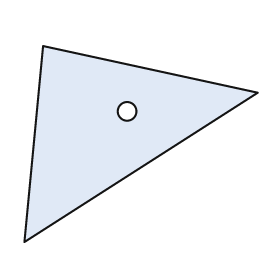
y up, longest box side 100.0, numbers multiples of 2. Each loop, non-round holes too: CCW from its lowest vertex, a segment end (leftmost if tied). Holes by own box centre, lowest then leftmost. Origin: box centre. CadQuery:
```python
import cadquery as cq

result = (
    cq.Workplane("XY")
    .moveTo(-50.0, -42.0)
    .lineTo(50.0, 22.0)
    .lineTo(-42.0, 42.0)
    .close()
    .moveTo(-6.0, 14.0)
    .circle(4.0)
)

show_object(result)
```